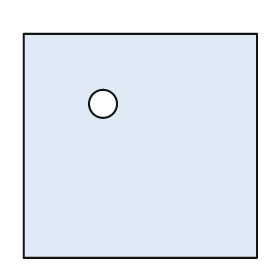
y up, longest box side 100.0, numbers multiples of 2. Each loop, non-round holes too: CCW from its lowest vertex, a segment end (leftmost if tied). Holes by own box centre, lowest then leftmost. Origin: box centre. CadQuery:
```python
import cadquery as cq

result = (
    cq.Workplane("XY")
    .moveTo(-50.0, -48.0)
    .lineTo(50.0, -48.0)
    .lineTo(50.0, 48.0)
    .lineTo(-50.0, 48.0)
    .close()
    .moveTo(-16.0, 18.0)
    .circle(6.0)
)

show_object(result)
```